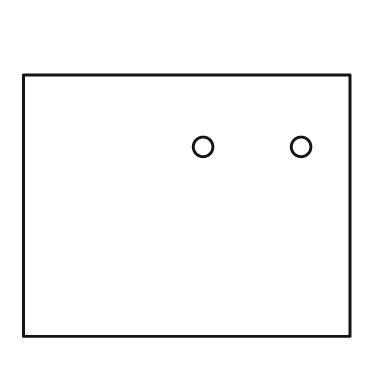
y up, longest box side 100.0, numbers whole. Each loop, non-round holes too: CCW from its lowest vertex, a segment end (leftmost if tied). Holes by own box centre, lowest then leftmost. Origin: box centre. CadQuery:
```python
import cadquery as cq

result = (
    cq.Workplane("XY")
    .moveTo(-50.0, -40.0)
    .lineTo(50.0, -40.0)
    .lineTo(50.0, 40.0)
    .lineTo(-50.0, 40.0)
    .close()
    .moveTo(5.0, 18.0)
    .circle(3.0)
    .moveTo(35.0, 18.0)
    .circle(3.0)
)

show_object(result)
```